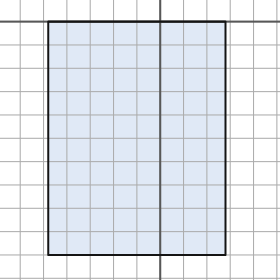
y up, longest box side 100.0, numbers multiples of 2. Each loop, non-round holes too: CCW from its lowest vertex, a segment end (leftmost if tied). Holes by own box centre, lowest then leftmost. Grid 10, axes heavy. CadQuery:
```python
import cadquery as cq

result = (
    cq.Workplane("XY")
    .moveTo(-48.0, -100.0)
    .lineTo(28.0, -100.0)
    .lineTo(28.0, 0.0)
    .lineTo(-48.0, 0.0)
    .close()
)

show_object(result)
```